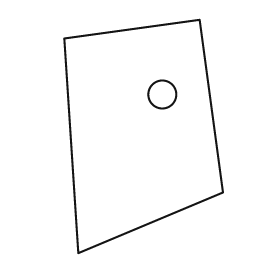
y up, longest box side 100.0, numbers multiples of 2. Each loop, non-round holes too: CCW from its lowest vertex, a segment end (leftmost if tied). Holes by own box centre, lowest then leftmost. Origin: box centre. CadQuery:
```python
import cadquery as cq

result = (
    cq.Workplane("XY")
    .moveTo(-28.0, -50.0)
    .lineTo(34.0, -24.0)
    .lineTo(24.0, 50.0)
    .lineTo(-34.0, 42.0)
    .close()
    .moveTo(8.0, 18.0)
    .circle(6.0)
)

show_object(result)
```